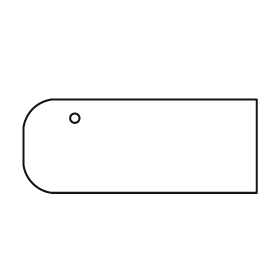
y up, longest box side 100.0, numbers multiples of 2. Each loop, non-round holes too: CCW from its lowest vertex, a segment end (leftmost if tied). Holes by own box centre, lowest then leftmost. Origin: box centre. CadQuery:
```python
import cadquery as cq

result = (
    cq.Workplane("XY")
    .moveTo(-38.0, -20.0)
    .lineTo(50.0, -20.0)
    .lineTo(50.0, 20.0)
    .lineTo(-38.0, 20.0)
    .threePointArc((-46.0, 16.0), (-50.0, 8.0))
    .lineTo(-50.0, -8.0)
    .threePointArc((-46.0, -16.0), (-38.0, -20.0))
    .close()
    .moveTo(-28.0, 12.0)
    .circle(2.0)
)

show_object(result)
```